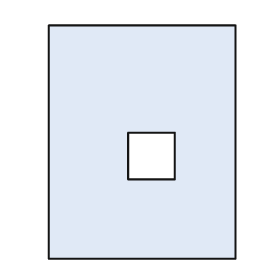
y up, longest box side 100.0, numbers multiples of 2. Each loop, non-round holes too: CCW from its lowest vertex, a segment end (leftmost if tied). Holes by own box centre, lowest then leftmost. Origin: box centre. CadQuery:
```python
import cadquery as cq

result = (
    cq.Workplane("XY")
    .moveTo(-40.0, -50.0)
    .lineTo(40.0, -50.0)
    .lineTo(40.0, 50.0)
    .lineTo(-40.0, 50.0)
    .close()
    .moveTo(-6.0, -16.0)
    .lineTo(14.0, -16.0)
    .lineTo(14.0, 4.0)
    .lineTo(-6.0, 4.0)
    .close()
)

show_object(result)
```